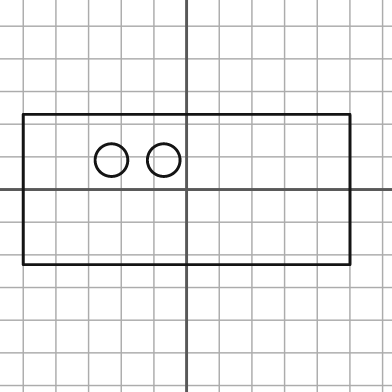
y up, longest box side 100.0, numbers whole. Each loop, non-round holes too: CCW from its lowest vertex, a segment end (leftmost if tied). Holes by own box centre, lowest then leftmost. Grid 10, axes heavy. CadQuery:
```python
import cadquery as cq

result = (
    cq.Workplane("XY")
    .moveTo(-50.0, -23.0)
    .lineTo(50.0, -23.0)
    .lineTo(50.0, 23.0)
    .lineTo(-50.0, 23.0)
    .close()
    .moveTo(-23.0, 9.0)
    .circle(5.0)
    .moveTo(-7.0, 9.0)
    .circle(5.0)
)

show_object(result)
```